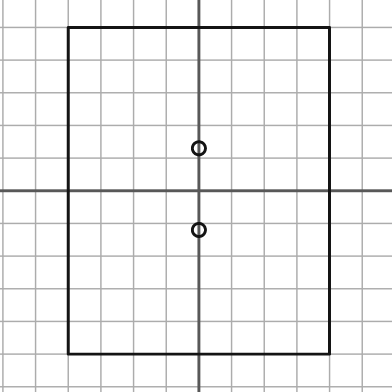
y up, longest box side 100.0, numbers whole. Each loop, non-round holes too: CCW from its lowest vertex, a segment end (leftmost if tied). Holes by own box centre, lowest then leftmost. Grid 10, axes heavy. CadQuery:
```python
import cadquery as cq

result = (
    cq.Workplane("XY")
    .moveTo(-40.0, -50.0)
    .lineTo(40.0, -50.0)
    .lineTo(40.0, 50.0)
    .lineTo(-40.0, 50.0)
    .close()
    .moveTo(0.0, -12.0)
    .circle(2.0)
    .moveTo(0.0, 13.0)
    .circle(2.0)
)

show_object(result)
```